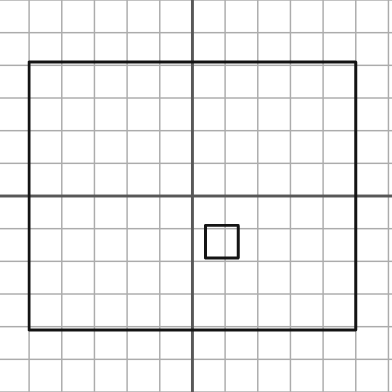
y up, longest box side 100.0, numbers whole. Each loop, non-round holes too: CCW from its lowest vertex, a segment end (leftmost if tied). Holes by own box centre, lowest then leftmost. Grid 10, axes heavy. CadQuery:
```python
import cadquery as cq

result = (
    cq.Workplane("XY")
    .moveTo(-50.0, -41.0)
    .lineTo(50.0, -41.0)
    .lineTo(50.0, 41.0)
    .lineTo(-50.0, 41.0)
    .close()
    .moveTo(4.0, -19.0)
    .lineTo(14.0, -19.0)
    .lineTo(14.0, -9.0)
    .lineTo(4.0, -9.0)
    .close()
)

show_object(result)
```